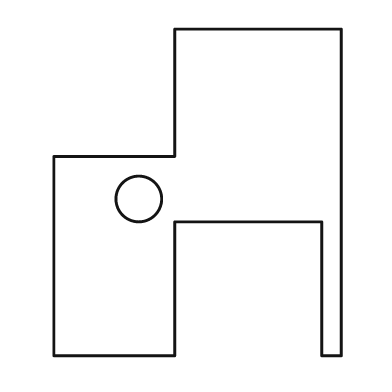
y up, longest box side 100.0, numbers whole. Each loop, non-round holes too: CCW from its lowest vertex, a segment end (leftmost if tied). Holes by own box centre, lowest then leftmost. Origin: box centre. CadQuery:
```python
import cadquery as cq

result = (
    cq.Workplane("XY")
    .moveTo(-44.0, -50.0)
    .lineTo(-7.0, -50.0)
    .lineTo(-7.0, -9.0)
    .lineTo(38.0, -9.0)
    .lineTo(38.0, -50.0)
    .lineTo(44.0, -50.0)
    .lineTo(44.0, 50.0)
    .lineTo(-7.0, 50.0)
    .lineTo(-7.0, 11.0)
    .lineTo(-44.0, 11.0)
    .close()
    .moveTo(-18.0, -2.0)
    .circle(7.0)
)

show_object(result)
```